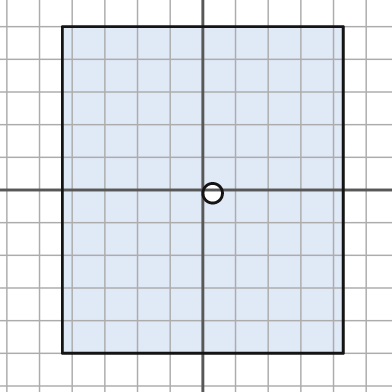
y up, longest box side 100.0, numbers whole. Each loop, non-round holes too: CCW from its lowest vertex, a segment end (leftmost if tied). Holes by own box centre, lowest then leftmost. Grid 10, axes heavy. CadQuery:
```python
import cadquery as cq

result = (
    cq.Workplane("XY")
    .moveTo(-43.0, -50.0)
    .lineTo(43.0, -50.0)
    .lineTo(43.0, 50.0)
    .lineTo(-43.0, 50.0)
    .close()
    .moveTo(3.0, -1.0)
    .circle(3.0)
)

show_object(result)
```